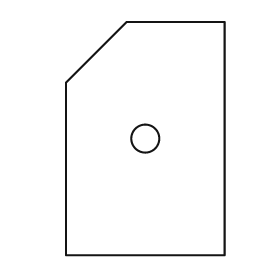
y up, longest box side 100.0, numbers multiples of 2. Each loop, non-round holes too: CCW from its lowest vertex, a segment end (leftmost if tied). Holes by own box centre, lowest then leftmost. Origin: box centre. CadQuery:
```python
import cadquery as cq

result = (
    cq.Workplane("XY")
    .moveTo(-34.0, -50.0)
    .lineTo(34.0, -50.0)
    .lineTo(34.0, 50.0)
    .lineTo(-8.0, 50.0)
    .lineTo(-34.0, 24.0)
    .close()
    .moveTo(0.0, 0.0)
    .circle(6.0)
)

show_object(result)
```